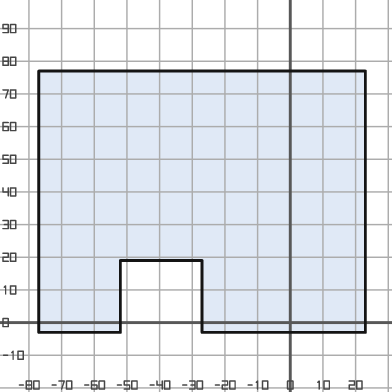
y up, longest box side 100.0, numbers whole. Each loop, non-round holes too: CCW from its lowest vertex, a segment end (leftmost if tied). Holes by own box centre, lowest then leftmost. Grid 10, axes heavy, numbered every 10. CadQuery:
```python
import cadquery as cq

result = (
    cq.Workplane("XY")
    .moveTo(-77.0, -3.0)
    .lineTo(-52.0, -3.0)
    .lineTo(-52.0, 19.0)
    .lineTo(-27.0, 19.0)
    .lineTo(-27.0, -3.0)
    .lineTo(23.0, -3.0)
    .lineTo(23.0, 77.0)
    .lineTo(-77.0, 77.0)
    .close()
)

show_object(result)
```